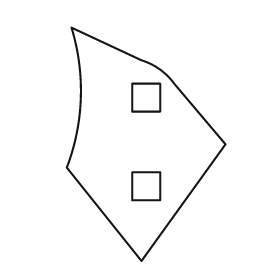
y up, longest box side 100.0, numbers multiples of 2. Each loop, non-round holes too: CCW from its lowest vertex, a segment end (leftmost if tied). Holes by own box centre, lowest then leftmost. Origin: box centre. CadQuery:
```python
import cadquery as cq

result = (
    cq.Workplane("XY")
    .moveTo(-2.0, -50.0)
    .lineTo(34.0, 0.0)
    .lineTo(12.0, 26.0)
    .threePointArc((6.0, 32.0), (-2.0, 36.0))
    .lineTo(-32.0, 50.0)
    .threePointArc((-28.0, 20.0), (-34.0, -10.0))
    .close()
    .moveTo(-6.0, -24.0)
    .lineTo(6.0, -24.0)
    .lineTo(6.0, -12.0)
    .lineTo(-6.0, -12.0)
    .close()
    .moveTo(-6.0, 14.0)
    .lineTo(6.0, 14.0)
    .lineTo(6.0, 26.0)
    .lineTo(-6.0, 26.0)
    .close()
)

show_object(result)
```